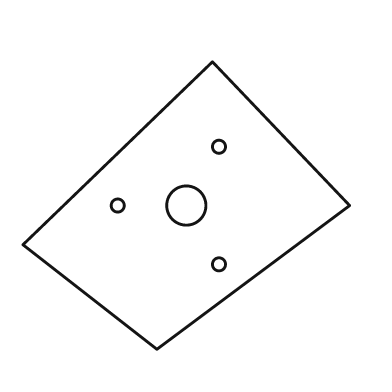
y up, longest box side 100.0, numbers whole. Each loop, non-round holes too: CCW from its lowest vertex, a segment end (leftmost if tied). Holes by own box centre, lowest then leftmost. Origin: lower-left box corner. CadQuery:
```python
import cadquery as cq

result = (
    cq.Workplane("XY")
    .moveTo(41.0, 0.0)
    .lineTo(100.0, 44.0)
    .lineTo(58.0, 88.0)
    .lineTo(0.0, 32.0)
    .close()
    .moveTo(60.0, 26.0)
    .circle(2.0)
    .moveTo(29.0, 44.0)
    .circle(2.0)
    .moveTo(50.0, 44.0)
    .circle(6.0)
    .moveTo(60.0, 62.0)
    .circle(2.0)
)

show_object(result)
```